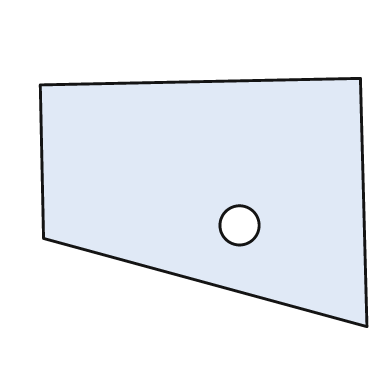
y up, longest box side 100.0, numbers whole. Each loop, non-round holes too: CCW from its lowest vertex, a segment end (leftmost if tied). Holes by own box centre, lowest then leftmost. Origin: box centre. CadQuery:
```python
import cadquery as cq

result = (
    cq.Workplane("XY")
    .moveTo(50.0, -38.0)
    .lineTo(48.0, 38.0)
    .lineTo(-50.0, 36.0)
    .lineTo(-49.0, -11.0)
    .close()
    .moveTo(11.0, -7.0)
    .circle(6.0)
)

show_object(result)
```